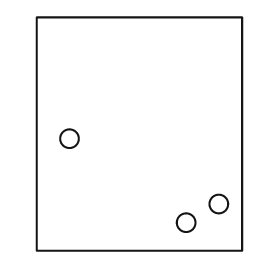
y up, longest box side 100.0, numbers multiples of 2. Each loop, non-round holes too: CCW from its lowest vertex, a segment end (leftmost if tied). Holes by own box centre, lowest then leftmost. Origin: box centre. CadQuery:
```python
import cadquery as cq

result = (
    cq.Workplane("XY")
    .moveTo(-44.0, -50.0)
    .lineTo(44.0, -50.0)
    .lineTo(44.0, 50.0)
    .lineTo(-44.0, 50.0)
    .close()
    .moveTo(20.0, -38.0)
    .circle(4.0)
    .moveTo(34.0, -30.0)
    .circle(4.0)
    .moveTo(-30.0, -2.0)
    .circle(4.0)
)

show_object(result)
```